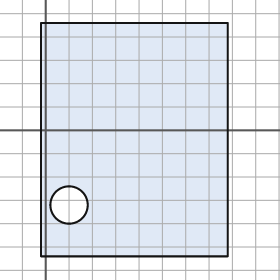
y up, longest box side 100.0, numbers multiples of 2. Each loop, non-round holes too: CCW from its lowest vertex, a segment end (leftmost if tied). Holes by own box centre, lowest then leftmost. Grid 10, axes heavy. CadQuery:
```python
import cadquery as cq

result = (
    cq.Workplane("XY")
    .moveTo(-2.0, -54.0)
    .lineTo(78.0, -54.0)
    .lineTo(78.0, 46.0)
    .lineTo(-2.0, 46.0)
    .close()
    .moveTo(10.0, -32.0)
    .circle(8.0)
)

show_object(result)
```